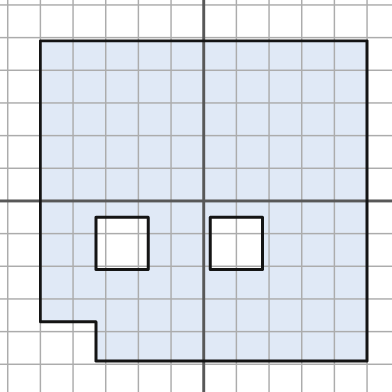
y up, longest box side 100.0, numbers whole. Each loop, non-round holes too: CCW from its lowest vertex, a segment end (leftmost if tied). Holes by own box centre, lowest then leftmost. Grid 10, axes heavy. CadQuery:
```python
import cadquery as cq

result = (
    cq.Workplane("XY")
    .moveTo(-33.0, -49.0)
    .lineTo(50.0, -49.0)
    .lineTo(50.0, 49.0)
    .lineTo(-50.0, 49.0)
    .lineTo(-50.0, -37.0)
    .lineTo(-33.0, -37.0)
    .close()
    .moveTo(-33.0, -21.0)
    .lineTo(-17.0, -21.0)
    .lineTo(-17.0, -5.0)
    .lineTo(-33.0, -5.0)
    .close()
    .moveTo(2.0, -21.0)
    .lineTo(18.0, -21.0)
    .lineTo(18.0, -5.0)
    .lineTo(2.0, -5.0)
    .close()
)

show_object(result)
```